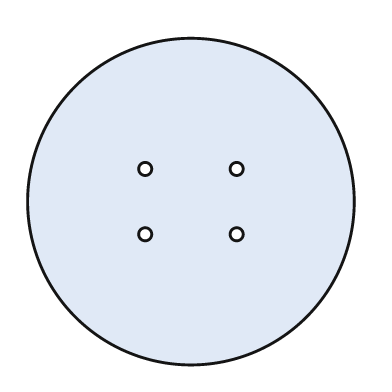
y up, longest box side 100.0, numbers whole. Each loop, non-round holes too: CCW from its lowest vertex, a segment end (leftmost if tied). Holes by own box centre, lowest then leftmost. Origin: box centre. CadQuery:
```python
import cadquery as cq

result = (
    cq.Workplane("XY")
    .moveTo(0.0, 0.0)
    .circle(50.0)
    .moveTo(-14.0, -10.0)
    .circle(2.0)
    .moveTo(14.0, -10.0)
    .circle(2.0)
    .moveTo(-14.0, 10.0)
    .circle(2.0)
    .moveTo(14.0, 10.0)
    .circle(2.0)
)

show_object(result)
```